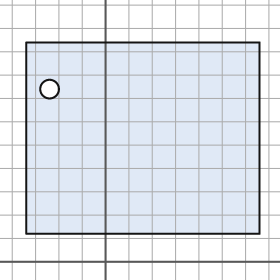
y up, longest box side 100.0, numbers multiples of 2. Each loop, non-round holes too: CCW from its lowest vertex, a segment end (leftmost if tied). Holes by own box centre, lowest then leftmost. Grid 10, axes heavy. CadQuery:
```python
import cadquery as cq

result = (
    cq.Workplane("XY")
    .moveTo(-34.0, 12.0)
    .lineTo(66.0, 12.0)
    .lineTo(66.0, 94.0)
    .lineTo(-34.0, 94.0)
    .close()
    .moveTo(-24.0, 74.0)
    .circle(4.0)
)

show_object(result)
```